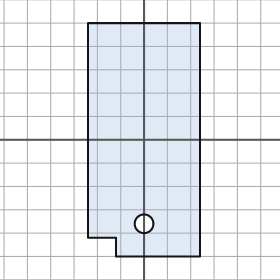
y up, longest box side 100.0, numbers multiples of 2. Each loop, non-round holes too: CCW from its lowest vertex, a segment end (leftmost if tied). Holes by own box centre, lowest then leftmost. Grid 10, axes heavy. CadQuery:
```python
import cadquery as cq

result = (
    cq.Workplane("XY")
    .moveTo(-12.0, -50.0)
    .lineTo(24.0, -50.0)
    .lineTo(24.0, 50.0)
    .lineTo(-24.0, 50.0)
    .lineTo(-24.0, -42.0)
    .lineTo(-12.0, -42.0)
    .close()
    .moveTo(0.0, -36.0)
    .circle(4.0)
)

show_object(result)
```